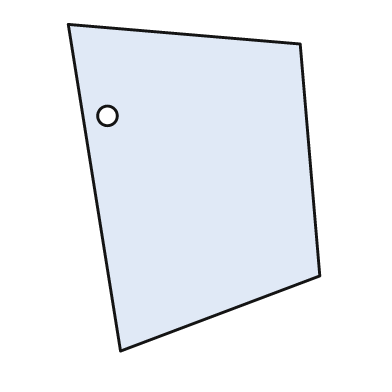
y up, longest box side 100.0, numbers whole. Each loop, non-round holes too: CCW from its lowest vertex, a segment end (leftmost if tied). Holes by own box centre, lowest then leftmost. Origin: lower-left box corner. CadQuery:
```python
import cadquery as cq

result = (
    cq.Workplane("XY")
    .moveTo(16.0, 0.0)
    .lineTo(77.0, 23.0)
    .lineTo(71.0, 94.0)
    .lineTo(0.0, 100.0)
    .close()
    .moveTo(12.0, 72.0)
    .circle(3.0)
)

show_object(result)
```